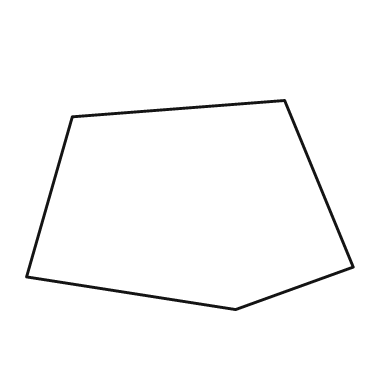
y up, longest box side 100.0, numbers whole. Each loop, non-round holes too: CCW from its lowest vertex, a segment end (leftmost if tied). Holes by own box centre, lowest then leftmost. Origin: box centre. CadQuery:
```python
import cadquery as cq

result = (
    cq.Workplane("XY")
    .moveTo(14.0, -32.0)
    .lineTo(50.0, -19.0)
    .lineTo(29.0, 32.0)
    .lineTo(-36.0, 27.0)
    .lineTo(-50.0, -22.0)
    .close()
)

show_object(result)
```